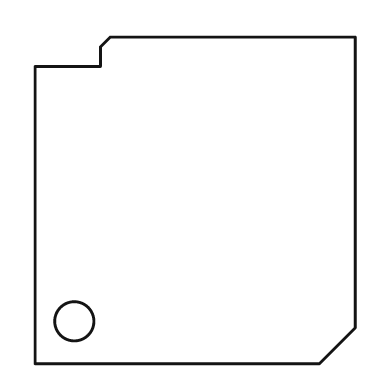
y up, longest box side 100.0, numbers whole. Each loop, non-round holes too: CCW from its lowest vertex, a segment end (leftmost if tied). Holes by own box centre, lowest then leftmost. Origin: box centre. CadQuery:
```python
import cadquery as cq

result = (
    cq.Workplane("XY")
    .moveTo(-49.0, -50.0)
    .lineTo(38.0, -50.0)
    .lineTo(49.0, -39.0)
    .lineTo(49.0, 50.0)
    .lineTo(-26.0, 50.0)
    .lineTo(-29.0, 47.0)
    .lineTo(-29.0, 41.0)
    .lineTo(-49.0, 41.0)
    .close()
    .moveTo(-37.0, -37.0)
    .circle(6.0)
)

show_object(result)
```